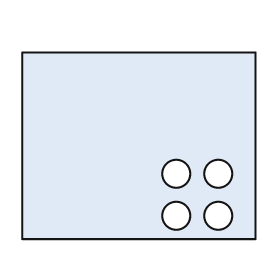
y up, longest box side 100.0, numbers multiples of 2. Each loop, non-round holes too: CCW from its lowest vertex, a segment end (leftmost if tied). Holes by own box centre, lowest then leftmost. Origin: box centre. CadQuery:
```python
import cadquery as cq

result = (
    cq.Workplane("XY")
    .moveTo(-50.0, -40.0)
    .lineTo(50.0, -40.0)
    .lineTo(50.0, 40.0)
    .lineTo(-50.0, 40.0)
    .close()
    .moveTo(16.0, -30.0)
    .circle(6.0)
    .moveTo(34.0, -30.0)
    .circle(6.0)
    .moveTo(16.0, -12.0)
    .circle(6.0)
    .moveTo(34.0, -12.0)
    .circle(6.0)
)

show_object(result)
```